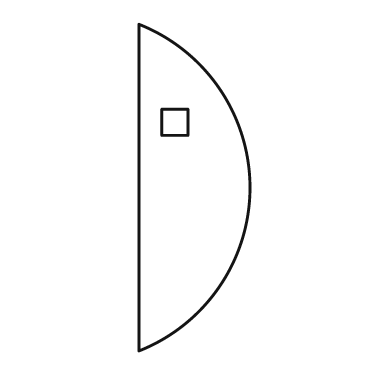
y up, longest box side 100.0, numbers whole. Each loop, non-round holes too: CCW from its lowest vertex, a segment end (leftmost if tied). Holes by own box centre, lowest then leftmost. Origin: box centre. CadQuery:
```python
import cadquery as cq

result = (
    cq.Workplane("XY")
    .moveTo(-17.0, -50.0)
    .threePointArc((17.0, 0.0), (-17.0, 50.0))
    .close()
    .moveTo(-10.0, 16.0)
    .lineTo(-2.0, 16.0)
    .lineTo(-2.0, 24.0)
    .lineTo(-10.0, 24.0)
    .close()
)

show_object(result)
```